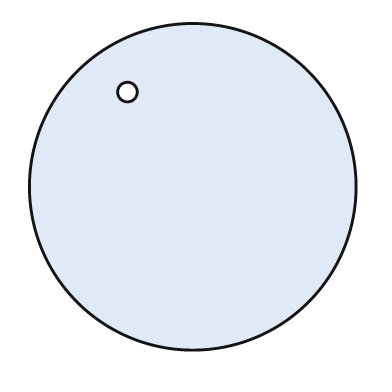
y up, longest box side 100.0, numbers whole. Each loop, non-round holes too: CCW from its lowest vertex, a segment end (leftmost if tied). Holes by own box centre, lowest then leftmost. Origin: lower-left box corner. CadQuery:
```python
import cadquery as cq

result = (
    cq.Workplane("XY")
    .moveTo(50.0, 50.0)
    .circle(50.0)
    .moveTo(30.0, 79.0)
    .circle(3.0)
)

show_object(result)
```